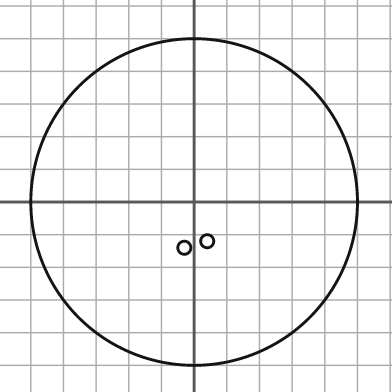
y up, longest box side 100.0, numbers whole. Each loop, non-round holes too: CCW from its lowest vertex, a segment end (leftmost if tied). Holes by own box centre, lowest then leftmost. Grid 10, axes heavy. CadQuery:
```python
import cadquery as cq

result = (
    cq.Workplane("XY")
    .moveTo(0.0, 0.0)
    .circle(50.0)
    .moveTo(-3.0, -14.0)
    .circle(2.0)
    .moveTo(4.0, -12.0)
    .circle(2.0)
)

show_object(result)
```